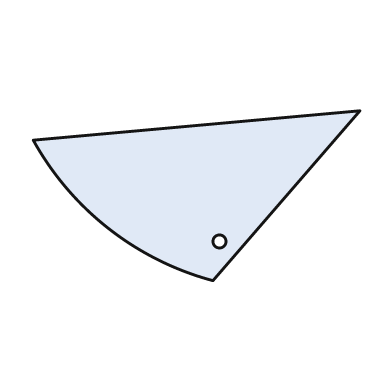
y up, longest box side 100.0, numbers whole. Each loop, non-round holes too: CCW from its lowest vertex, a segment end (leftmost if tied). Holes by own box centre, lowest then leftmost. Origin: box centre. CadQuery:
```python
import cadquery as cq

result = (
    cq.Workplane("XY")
    .moveTo(5.0, -26.0)
    .lineTo(50.0, 26.0)
    .lineTo(-50.0, 17.0)
    .threePointArc((-27.0, -10.0), (5.0, -26.0))
    .close()
    .moveTo(7.0, -14.0)
    .circle(2.0)
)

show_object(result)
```